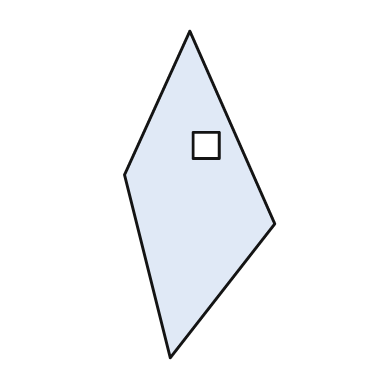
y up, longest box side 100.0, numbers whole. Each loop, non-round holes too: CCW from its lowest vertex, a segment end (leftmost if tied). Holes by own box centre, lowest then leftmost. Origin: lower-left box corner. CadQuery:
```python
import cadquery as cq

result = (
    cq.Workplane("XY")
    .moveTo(14.0, 0.0)
    .lineTo(46.0, 41.0)
    .lineTo(20.0, 100.0)
    .lineTo(0.0, 56.0)
    .close()
    .moveTo(21.0, 61.0)
    .lineTo(29.0, 61.0)
    .lineTo(29.0, 69.0)
    .lineTo(21.0, 69.0)
    .close()
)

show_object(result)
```